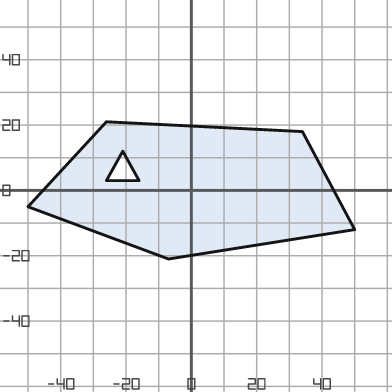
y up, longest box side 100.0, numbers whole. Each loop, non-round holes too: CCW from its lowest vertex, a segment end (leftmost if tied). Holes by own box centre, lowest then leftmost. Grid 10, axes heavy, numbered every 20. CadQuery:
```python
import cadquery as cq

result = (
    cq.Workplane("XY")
    .moveTo(-7.0, -21.0)
    .lineTo(50.0, -12.0)
    .lineTo(34.0, 18.0)
    .lineTo(-26.0, 21.0)
    .lineTo(-50.0, -5.0)
    .close()
    .moveTo(-26.0, 3.0)
    .lineTo(-16.0, 3.0)
    .lineTo(-21.0, 12.0)
    .close()
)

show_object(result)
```